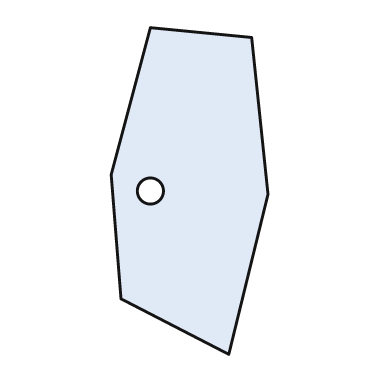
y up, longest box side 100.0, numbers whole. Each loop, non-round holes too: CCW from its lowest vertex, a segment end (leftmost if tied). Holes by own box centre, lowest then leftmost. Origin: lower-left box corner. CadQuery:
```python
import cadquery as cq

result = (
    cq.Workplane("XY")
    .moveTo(36.0, 0.0)
    .lineTo(48.0, 49.0)
    .lineTo(43.0, 97.0)
    .lineTo(12.0, 100.0)
    .lineTo(0.0, 55.0)
    .lineTo(3.0, 17.0)
    .close()
    .moveTo(12.0, 50.0)
    .circle(4.0)
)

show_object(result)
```